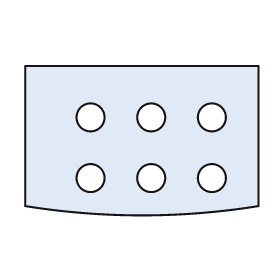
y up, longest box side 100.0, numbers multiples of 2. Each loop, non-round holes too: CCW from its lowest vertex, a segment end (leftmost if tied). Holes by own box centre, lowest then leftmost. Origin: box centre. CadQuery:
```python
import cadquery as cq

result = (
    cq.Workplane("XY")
    .moveTo(-50.0, -28.0)
    .threePointArc((0.0, -32.0), (50.0, -28.0))
    .lineTo(50.0, 32.0)
    .lineTo(-50.0, 32.0)
    .close()
    .moveTo(-22.0, -16.0)
    .circle(6.0)
    .moveTo(4.0, -16.0)
    .circle(6.0)
    .moveTo(30.0, -16.0)
    .circle(6.0)
    .moveTo(-22.0, 10.0)
    .circle(6.0)
    .moveTo(4.0, 10.0)
    .circle(6.0)
    .moveTo(30.0, 10.0)
    .circle(6.0)
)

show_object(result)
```